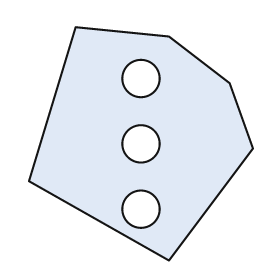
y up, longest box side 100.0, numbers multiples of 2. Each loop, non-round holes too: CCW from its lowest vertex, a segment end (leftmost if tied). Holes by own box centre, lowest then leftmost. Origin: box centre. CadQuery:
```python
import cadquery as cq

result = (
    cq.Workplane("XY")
    .moveTo(12.0, -50.0)
    .lineTo(48.0, -2.0)
    .lineTo(38.0, 26.0)
    .lineTo(12.0, 46.0)
    .lineTo(-28.0, 50.0)
    .lineTo(-48.0, -16.0)
    .close()
    .moveTo(0.0, -28.0)
    .circle(8.0)
    .moveTo(0.0, 0.0)
    .circle(8.0)
    .moveTo(0.0, 28.0)
    .circle(8.0)
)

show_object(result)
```